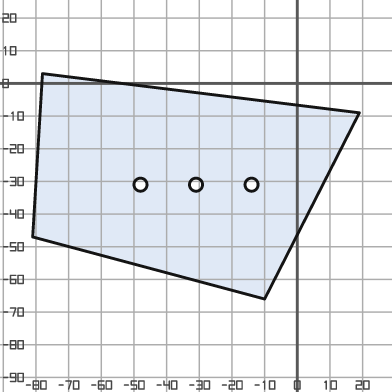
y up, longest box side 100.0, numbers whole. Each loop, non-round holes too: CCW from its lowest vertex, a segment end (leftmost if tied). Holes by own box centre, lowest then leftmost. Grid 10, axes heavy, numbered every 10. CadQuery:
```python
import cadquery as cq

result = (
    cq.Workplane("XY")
    .moveTo(-10.0, -66.0)
    .lineTo(19.0, -9.0)
    .lineTo(-78.0, 3.0)
    .lineTo(-81.0, -47.0)
    .close()
    .moveTo(-48.0, -31.0)
    .circle(2.0)
    .moveTo(-31.0, -31.0)
    .circle(2.0)
    .moveTo(-14.0, -31.0)
    .circle(2.0)
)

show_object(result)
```